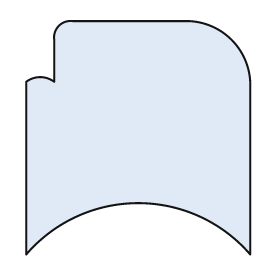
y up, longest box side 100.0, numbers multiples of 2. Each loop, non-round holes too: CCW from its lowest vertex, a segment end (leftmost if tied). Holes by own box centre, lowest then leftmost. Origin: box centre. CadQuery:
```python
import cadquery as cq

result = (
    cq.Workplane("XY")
    .moveTo(-48.0, -50.0)
    .threePointArc((0.0, -28.0), (48.0, -50.0))
    .lineTo(48.0, 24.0)
    .threePointArc((40.0, 42.0), (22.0, 50.0))
    .lineTo(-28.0, 50.0)
    .threePointArc((-34.0, 48.0), (-36.0, 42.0))
    .lineTo(-36.0, 24.0)
    .threePointArc((-42.0, 26.0), (-48.0, 24.0))
    .close()
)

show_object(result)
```